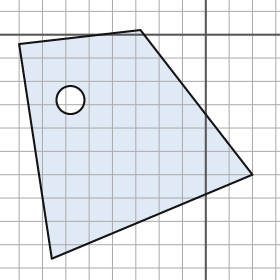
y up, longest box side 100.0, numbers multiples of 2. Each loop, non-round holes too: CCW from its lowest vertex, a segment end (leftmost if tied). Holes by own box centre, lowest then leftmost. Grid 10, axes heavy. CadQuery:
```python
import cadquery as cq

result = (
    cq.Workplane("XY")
    .moveTo(-66.0, -96.0)
    .lineTo(20.0, -60.0)
    .lineTo(-28.0, 2.0)
    .lineTo(-80.0, -4.0)
    .close()
    .moveTo(-58.0, -28.0)
    .circle(6.0)
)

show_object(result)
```